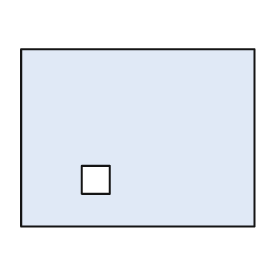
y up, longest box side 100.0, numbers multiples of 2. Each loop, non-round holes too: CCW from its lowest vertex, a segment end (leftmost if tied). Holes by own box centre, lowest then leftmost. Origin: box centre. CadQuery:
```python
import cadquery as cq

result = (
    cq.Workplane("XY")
    .moveTo(-50.0, -38.0)
    .lineTo(50.0, -38.0)
    .lineTo(50.0, 38.0)
    .lineTo(-50.0, 38.0)
    .close()
    .moveTo(-24.0, -24.0)
    .lineTo(-12.0, -24.0)
    .lineTo(-12.0, -12.0)
    .lineTo(-24.0, -12.0)
    .close()
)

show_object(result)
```